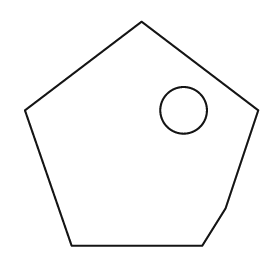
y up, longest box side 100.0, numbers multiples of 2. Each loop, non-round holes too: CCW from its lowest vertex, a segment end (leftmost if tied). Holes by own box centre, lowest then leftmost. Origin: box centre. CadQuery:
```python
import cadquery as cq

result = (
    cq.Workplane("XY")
    .moveTo(-30.0, -48.0)
    .lineTo(26.0, -48.0)
    .lineTo(36.0, -32.0)
    .lineTo(50.0, 10.0)
    .lineTo(0.0, 48.0)
    .lineTo(-50.0, 10.0)
    .close()
    .moveTo(18.0, 10.0)
    .circle(10.0)
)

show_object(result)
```